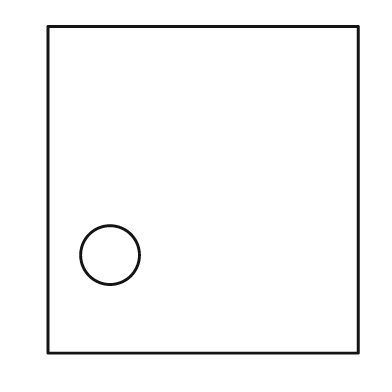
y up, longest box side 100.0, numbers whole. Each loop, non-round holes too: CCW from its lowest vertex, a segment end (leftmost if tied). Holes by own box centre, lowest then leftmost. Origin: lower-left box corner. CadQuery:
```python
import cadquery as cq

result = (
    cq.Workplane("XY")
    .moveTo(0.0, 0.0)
    .lineTo(95.0, 0.0)
    .lineTo(95.0, 100.0)
    .lineTo(0.0, 100.0)
    .close()
    .moveTo(19.0, 30.0)
    .circle(9.0)
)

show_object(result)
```